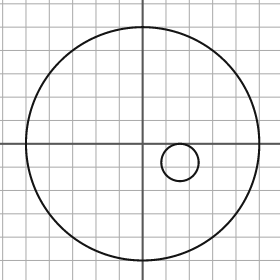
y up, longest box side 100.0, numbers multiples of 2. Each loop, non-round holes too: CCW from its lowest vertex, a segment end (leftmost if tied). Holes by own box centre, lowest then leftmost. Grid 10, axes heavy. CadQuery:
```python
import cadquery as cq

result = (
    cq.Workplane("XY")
    .moveTo(0.0, 0.0)
    .circle(50.0)
    .moveTo(16.0, -8.0)
    .circle(8.0)
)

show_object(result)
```